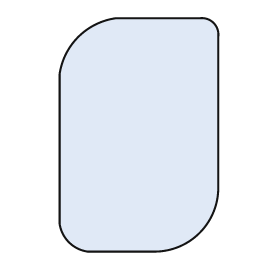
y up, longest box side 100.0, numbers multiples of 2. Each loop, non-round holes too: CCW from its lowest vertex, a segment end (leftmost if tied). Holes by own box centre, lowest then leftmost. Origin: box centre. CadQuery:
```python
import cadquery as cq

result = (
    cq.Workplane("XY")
    .moveTo(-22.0, -50.0)
    .lineTo(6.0, -50.0)
    .threePointArc((26.0, -42.0), (34.0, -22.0))
    .lineTo(34.0, 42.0)
    .threePointArc((32.0, 48.0), (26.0, 50.0))
    .lineTo(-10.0, 50.0)
    .threePointArc((-26.0, 42.0), (-34.0, 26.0))
    .lineTo(-34.0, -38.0)
    .threePointArc((-30.0, -46.0), (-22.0, -50.0))
    .close()
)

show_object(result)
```